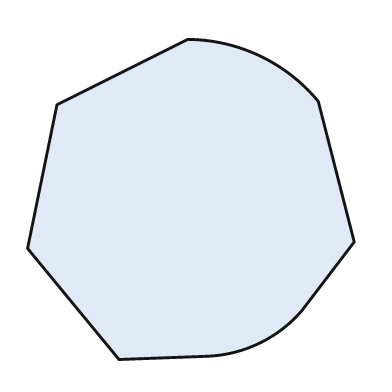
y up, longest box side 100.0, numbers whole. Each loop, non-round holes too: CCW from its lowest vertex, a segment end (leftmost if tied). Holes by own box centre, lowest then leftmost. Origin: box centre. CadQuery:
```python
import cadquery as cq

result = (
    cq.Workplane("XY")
    .moveTo(-22.0, -49.0)
    .lineTo(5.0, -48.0)
    .threePointArc((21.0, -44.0), (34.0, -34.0))
    .lineTo(50.0, -13.0)
    .lineTo(39.0, 30.0)
    .threePointArc((21.0, 44.0), (-1.0, 49.0))
    .lineTo(-41.0, 29.0)
    .lineTo(-50.0, -15.0)
    .close()
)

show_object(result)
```